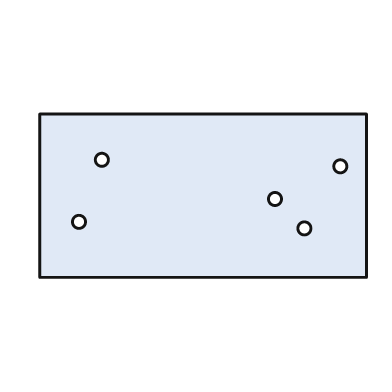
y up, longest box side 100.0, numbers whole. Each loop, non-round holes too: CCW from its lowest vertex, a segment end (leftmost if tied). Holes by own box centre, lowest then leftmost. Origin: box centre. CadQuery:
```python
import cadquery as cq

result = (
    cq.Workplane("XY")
    .moveTo(-50.0, -25.0)
    .lineTo(50.0, -25.0)
    .lineTo(50.0, 25.0)
    .lineTo(-50.0, 25.0)
    .close()
    .moveTo(31.0, -10.0)
    .circle(2.0)
    .moveTo(-38.0, -8.0)
    .circle(2.0)
    .moveTo(22.0, -1.0)
    .circle(2.0)
    .moveTo(42.0, 9.0)
    .circle(2.0)
    .moveTo(-31.0, 11.0)
    .circle(2.0)
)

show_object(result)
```